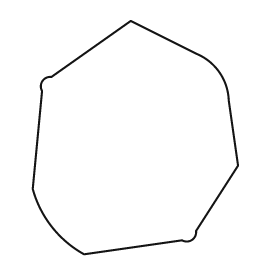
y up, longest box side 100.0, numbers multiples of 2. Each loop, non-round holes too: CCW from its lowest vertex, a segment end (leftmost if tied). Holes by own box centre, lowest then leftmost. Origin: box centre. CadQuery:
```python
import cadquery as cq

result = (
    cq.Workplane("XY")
    .moveTo(-22.0, -50.0)
    .lineTo(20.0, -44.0)
    .threePointArc((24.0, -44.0), (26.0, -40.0))
    .lineTo(44.0, -12.0)
    .lineTo(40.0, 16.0)
    .threePointArc((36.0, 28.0), (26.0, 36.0))
    .lineTo(-2.0, 50.0)
    .lineTo(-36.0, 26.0)
    .threePointArc((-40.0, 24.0), (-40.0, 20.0))
    .lineTo(-44.0, -22.0)
    .threePointArc((-36.0, -38.0), (-22.0, -50.0))
    .close()
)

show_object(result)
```